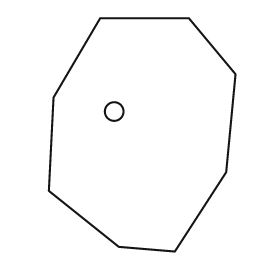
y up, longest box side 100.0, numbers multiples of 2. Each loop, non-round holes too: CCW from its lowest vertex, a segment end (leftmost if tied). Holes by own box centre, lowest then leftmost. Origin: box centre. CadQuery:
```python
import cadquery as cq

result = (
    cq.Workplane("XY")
    .moveTo(14.0, -50.0)
    .lineTo(36.0, -16.0)
    .lineTo(40.0, 26.0)
    .lineTo(20.0, 50.0)
    .lineTo(-18.0, 50.0)
    .lineTo(-38.0, 16.0)
    .lineTo(-40.0, -24.0)
    .lineTo(-10.0, -48.0)
    .close()
    .moveTo(-12.0, 10.0)
    .circle(4.0)
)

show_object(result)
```